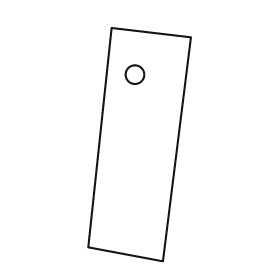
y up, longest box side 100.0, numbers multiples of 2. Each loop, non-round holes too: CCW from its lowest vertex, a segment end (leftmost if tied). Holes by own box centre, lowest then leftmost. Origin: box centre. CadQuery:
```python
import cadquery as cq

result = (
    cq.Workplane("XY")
    .moveTo(10.0, -50.0)
    .lineTo(22.0, 46.0)
    .lineTo(-12.0, 50.0)
    .lineTo(-22.0, -44.0)
    .close()
    .moveTo(-2.0, 30.0)
    .circle(4.0)
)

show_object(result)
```